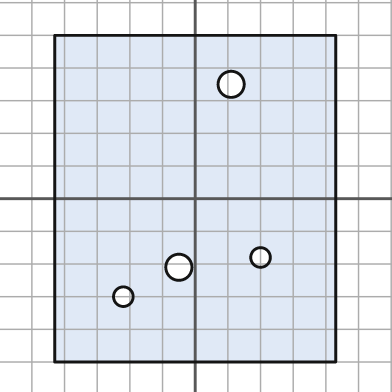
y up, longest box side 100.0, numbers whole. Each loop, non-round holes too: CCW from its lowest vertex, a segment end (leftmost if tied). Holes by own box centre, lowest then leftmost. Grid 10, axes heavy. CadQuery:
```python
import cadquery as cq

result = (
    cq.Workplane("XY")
    .moveTo(-43.0, -50.0)
    .lineTo(43.0, -50.0)
    .lineTo(43.0, 50.0)
    .lineTo(-43.0, 50.0)
    .close()
    .moveTo(-22.0, -30.0)
    .circle(3.0)
    .moveTo(-5.0, -21.0)
    .circle(4.0)
    .moveTo(20.0, -18.0)
    .circle(3.0)
    .moveTo(11.0, 35.0)
    .circle(4.0)
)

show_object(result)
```